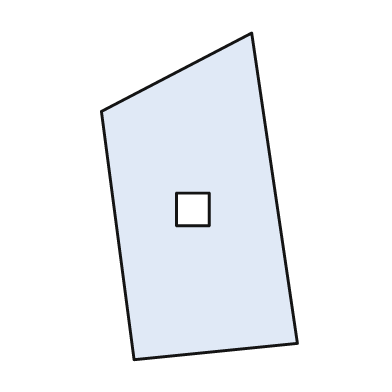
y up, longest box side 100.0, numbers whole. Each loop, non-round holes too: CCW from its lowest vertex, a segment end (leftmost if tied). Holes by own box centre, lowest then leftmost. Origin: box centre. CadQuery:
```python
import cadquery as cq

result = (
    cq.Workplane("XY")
    .moveTo(-20.0, -50.0)
    .lineTo(30.0, -45.0)
    .lineTo(16.0, 50.0)
    .lineTo(-30.0, 26.0)
    .close()
    .moveTo(-7.0, -9.0)
    .lineTo(3.0, -9.0)
    .lineTo(3.0, 1.0)
    .lineTo(-7.0, 1.0)
    .close()
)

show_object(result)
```